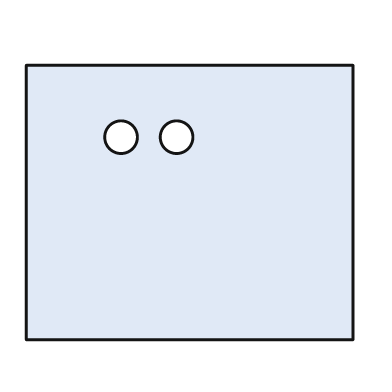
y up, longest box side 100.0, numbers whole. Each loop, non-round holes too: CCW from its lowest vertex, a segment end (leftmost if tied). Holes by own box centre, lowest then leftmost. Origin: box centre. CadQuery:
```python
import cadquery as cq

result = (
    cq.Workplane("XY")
    .moveTo(-50.0, -42.0)
    .lineTo(50.0, -42.0)
    .lineTo(50.0, 42.0)
    .lineTo(-50.0, 42.0)
    .close()
    .moveTo(-21.0, 20.0)
    .circle(5.0)
    .moveTo(-4.0, 20.0)
    .circle(5.0)
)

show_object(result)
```